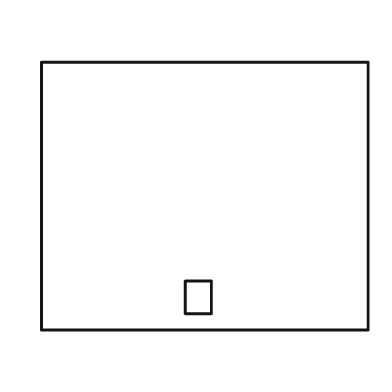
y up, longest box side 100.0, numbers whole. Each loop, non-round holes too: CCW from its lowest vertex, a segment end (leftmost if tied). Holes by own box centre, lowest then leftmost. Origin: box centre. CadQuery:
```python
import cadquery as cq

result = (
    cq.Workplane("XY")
    .moveTo(-50.0, -41.0)
    .lineTo(50.0, -41.0)
    .lineTo(50.0, 41.0)
    .lineTo(-50.0, 41.0)
    .close()
    .moveTo(-6.0, -36.0)
    .lineTo(2.0, -36.0)
    .lineTo(2.0, -26.0)
    .lineTo(-6.0, -26.0)
    .close()
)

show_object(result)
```